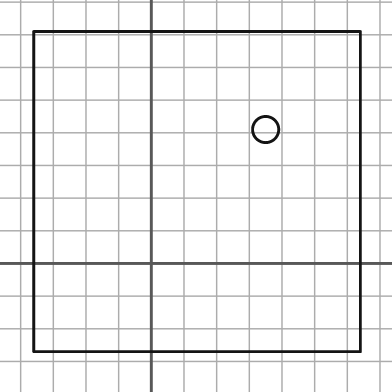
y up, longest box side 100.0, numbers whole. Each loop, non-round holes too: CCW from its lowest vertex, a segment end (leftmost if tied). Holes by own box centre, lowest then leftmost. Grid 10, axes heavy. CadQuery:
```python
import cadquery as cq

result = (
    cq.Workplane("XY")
    .moveTo(-36.0, -27.0)
    .lineTo(64.0, -27.0)
    .lineTo(64.0, 71.0)
    .lineTo(-36.0, 71.0)
    .close()
    .moveTo(35.0, 41.0)
    .circle(4.0)
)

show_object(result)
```